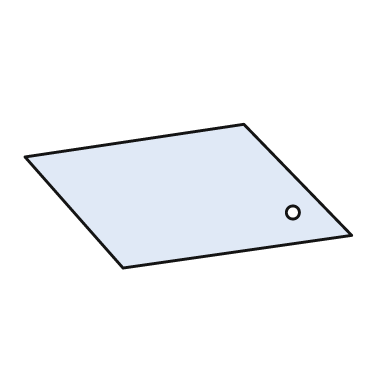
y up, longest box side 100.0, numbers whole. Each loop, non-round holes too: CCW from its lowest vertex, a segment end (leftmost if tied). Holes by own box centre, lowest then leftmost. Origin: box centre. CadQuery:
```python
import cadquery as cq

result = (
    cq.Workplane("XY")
    .moveTo(-20.0, -22.0)
    .lineTo(50.0, -12.0)
    .lineTo(17.0, 22.0)
    .lineTo(-50.0, 12.0)
    .close()
    .moveTo(32.0, -5.0)
    .circle(2.0)
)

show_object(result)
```